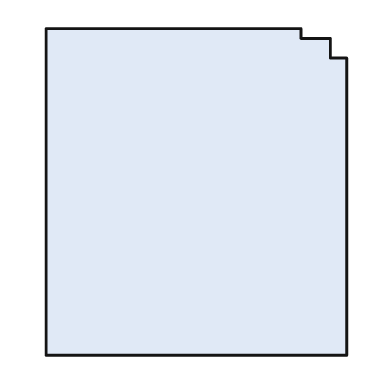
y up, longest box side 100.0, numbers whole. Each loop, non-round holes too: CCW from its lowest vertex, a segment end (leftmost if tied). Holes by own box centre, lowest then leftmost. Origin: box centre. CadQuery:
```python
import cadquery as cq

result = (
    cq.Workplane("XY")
    .moveTo(-46.0, -50.0)
    .lineTo(46.0, -50.0)
    .lineTo(46.0, 41.0)
    .lineTo(41.0, 41.0)
    .lineTo(41.0, 47.0)
    .lineTo(32.0, 47.0)
    .lineTo(32.0, 50.0)
    .lineTo(-46.0, 50.0)
    .close()
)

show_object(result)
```